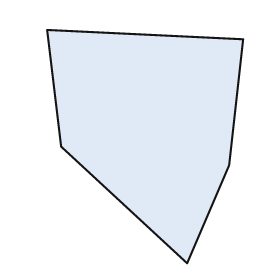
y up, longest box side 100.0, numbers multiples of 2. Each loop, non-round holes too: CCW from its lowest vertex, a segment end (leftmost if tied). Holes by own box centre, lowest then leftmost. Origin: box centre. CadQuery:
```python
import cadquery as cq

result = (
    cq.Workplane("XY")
    .moveTo(18.0, -50.0)
    .lineTo(36.0, -8.0)
    .lineTo(42.0, 46.0)
    .lineTo(-42.0, 50.0)
    .lineTo(-36.0, 0.0)
    .close()
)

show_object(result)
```